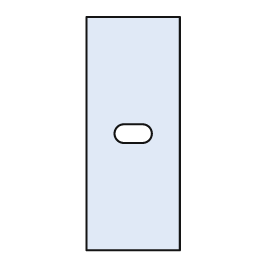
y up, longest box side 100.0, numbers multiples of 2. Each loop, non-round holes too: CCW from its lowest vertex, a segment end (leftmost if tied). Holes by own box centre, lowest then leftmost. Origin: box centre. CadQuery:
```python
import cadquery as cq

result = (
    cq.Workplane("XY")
    .moveTo(-20.0, -50.0)
    .lineTo(20.0, -50.0)
    .lineTo(20.0, 50.0)
    .lineTo(-20.0, 50.0)
    .close()
    .moveTo(-4.0, -4.0)
    .lineTo(4.0, -4.0)
    .threePointArc((8.0, 0.0), (4.0, 4.0))
    .lineTo(-4.0, 4.0)
    .threePointArc((-8.0, 0.0), (-4.0, -4.0))
    .close()
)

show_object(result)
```